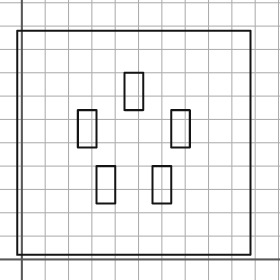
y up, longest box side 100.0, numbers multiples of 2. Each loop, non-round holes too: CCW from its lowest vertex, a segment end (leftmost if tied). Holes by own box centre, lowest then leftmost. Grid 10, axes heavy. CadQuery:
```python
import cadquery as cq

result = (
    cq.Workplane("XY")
    .moveTo(-2.0, 2.0)
    .lineTo(98.0, 2.0)
    .lineTo(98.0, 98.0)
    .lineTo(-2.0, 98.0)
    .close()
    .moveTo(32.0, 24.0)
    .lineTo(40.0, 24.0)
    .lineTo(40.0, 40.0)
    .lineTo(32.0, 40.0)
    .close()
    .moveTo(56.0, 24.0)
    .lineTo(64.0, 24.0)
    .lineTo(64.0, 40.0)
    .lineTo(56.0, 40.0)
    .close()
    .moveTo(24.0, 48.0)
    .lineTo(32.0, 48.0)
    .lineTo(32.0, 64.0)
    .lineTo(24.0, 64.0)
    .close()
    .moveTo(64.0, 48.0)
    .lineTo(72.0, 48.0)
    .lineTo(72.0, 64.0)
    .lineTo(64.0, 64.0)
    .close()
    .moveTo(44.0, 64.0)
    .lineTo(52.0, 64.0)
    .lineTo(52.0, 80.0)
    .lineTo(44.0, 80.0)
    .close()
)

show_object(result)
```